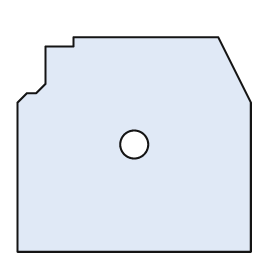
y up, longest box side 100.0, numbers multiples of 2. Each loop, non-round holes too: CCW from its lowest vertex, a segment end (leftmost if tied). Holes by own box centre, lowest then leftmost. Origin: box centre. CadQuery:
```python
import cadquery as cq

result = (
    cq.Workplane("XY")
    .moveTo(-50.0, -46.0)
    .lineTo(50.0, -46.0)
    .lineTo(50.0, 18.0)
    .lineTo(36.0, 46.0)
    .lineTo(-26.0, 46.0)
    .lineTo(-26.0, 42.0)
    .lineTo(-38.0, 42.0)
    .lineTo(-38.0, 26.0)
    .lineTo(-42.0, 22.0)
    .lineTo(-46.0, 22.0)
    .lineTo(-50.0, 18.0)
    .close()
    .moveTo(0.0, 0.0)
    .circle(6.0)
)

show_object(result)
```